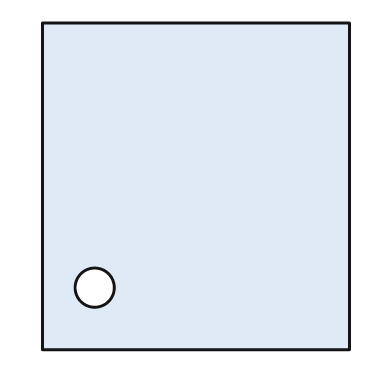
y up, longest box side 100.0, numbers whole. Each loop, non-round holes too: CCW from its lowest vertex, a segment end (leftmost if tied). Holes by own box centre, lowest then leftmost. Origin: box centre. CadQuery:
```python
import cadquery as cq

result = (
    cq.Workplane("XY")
    .moveTo(-47.0, -50.0)
    .lineTo(47.0, -50.0)
    .lineTo(47.0, 50.0)
    .lineTo(-47.0, 50.0)
    .close()
    .moveTo(-31.0, -31.0)
    .circle(6.0)
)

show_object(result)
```